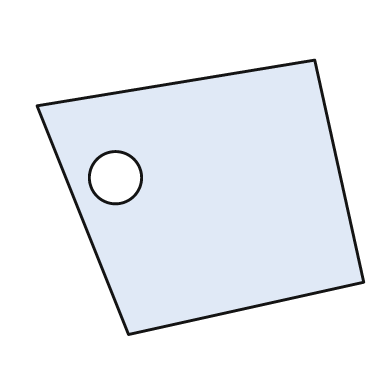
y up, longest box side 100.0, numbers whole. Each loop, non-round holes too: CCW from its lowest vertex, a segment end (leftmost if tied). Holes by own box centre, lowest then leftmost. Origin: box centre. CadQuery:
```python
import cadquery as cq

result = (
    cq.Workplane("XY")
    .moveTo(-22.0, -42.0)
    .lineTo(50.0, -26.0)
    .lineTo(35.0, 42.0)
    .lineTo(-50.0, 28.0)
    .close()
    .moveTo(-26.0, 6.0)
    .circle(8.0)
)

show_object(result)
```